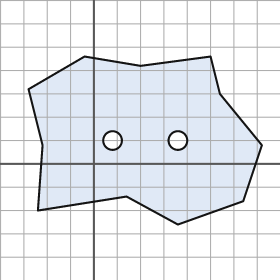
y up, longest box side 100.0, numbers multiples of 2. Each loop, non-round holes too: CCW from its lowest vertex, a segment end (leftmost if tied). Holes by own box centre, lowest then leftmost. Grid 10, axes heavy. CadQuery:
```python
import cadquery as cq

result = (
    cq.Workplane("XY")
    .moveTo(36.0, -26.0)
    .lineTo(64.0, -16.0)
    .lineTo(72.0, 8.0)
    .lineTo(54.0, 30.0)
    .lineTo(50.0, 46.0)
    .lineTo(20.0, 42.0)
    .lineTo(-4.0, 46.0)
    .lineTo(-28.0, 32.0)
    .lineTo(-22.0, 8.0)
    .lineTo(-24.0, -20.0)
    .lineTo(14.0, -14.0)
    .close()
    .moveTo(8.0, 10.0)
    .circle(4.0)
    .moveTo(36.0, 10.0)
    .circle(4.0)
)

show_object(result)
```